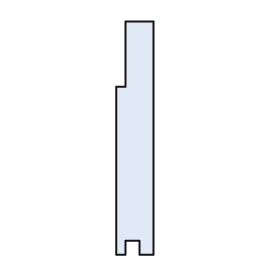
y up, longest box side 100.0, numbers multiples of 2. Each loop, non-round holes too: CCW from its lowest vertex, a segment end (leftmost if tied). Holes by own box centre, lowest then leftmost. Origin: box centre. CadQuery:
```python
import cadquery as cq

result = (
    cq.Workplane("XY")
    .moveTo(-8.0, -50.0)
    .lineTo(-4.0, -50.0)
    .lineTo(-4.0, -44.0)
    .lineTo(2.0, -44.0)
    .lineTo(2.0, -50.0)
    .lineTo(8.0, -50.0)
    .lineTo(8.0, 50.0)
    .lineTo(-4.0, 50.0)
    .lineTo(-4.0, 22.0)
    .lineTo(-8.0, 22.0)
    .close()
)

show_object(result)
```